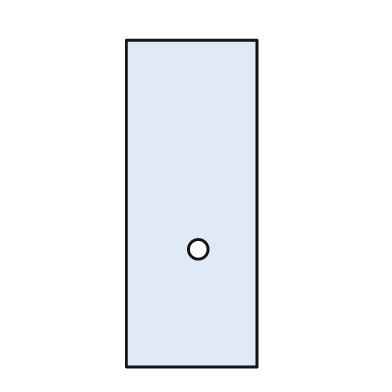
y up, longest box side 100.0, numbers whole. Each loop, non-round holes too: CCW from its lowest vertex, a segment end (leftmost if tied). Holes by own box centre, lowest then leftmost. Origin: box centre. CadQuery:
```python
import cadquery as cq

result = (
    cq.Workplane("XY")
    .moveTo(-20.0, -50.0)
    .lineTo(20.0, -50.0)
    .lineTo(20.0, 50.0)
    .lineTo(-20.0, 50.0)
    .close()
    .moveTo(2.0, -14.0)
    .circle(3.0)
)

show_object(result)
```